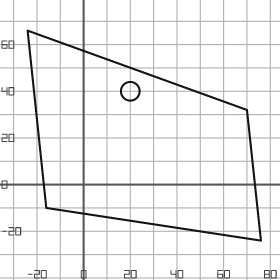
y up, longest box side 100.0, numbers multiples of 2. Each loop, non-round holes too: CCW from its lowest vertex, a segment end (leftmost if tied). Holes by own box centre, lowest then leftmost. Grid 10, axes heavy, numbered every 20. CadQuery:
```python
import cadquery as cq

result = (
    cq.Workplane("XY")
    .moveTo(76.0, -24.0)
    .lineTo(70.0, 32.0)
    .lineTo(-24.0, 66.0)
    .lineTo(-16.0, -10.0)
    .close()
    .moveTo(20.0, 40.0)
    .circle(4.0)
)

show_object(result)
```